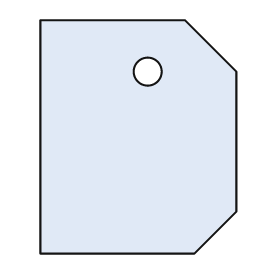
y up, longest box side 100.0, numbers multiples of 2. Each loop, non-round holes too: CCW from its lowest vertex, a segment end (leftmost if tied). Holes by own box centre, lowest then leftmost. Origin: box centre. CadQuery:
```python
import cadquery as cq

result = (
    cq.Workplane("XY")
    .moveTo(-42.0, -50.0)
    .lineTo(24.0, -50.0)
    .lineTo(42.0, -32.0)
    .lineTo(42.0, 28.0)
    .lineTo(20.0, 50.0)
    .lineTo(-42.0, 50.0)
    .close()
    .moveTo(4.0, 28.0)
    .circle(6.0)
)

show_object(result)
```